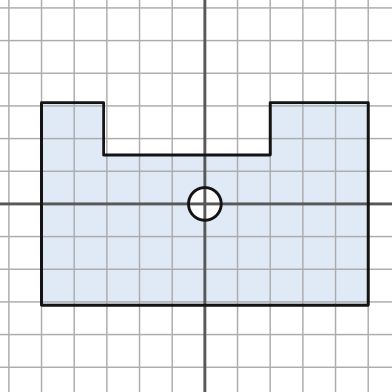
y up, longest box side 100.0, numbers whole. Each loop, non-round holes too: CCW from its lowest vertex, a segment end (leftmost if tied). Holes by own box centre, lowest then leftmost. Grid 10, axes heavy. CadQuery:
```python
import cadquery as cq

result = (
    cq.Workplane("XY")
    .moveTo(-50.0, -31.0)
    .lineTo(50.0, -31.0)
    .lineTo(50.0, 31.0)
    .lineTo(20.0, 31.0)
    .lineTo(20.0, 15.0)
    .lineTo(-31.0, 15.0)
    .lineTo(-31.0, 31.0)
    .lineTo(-50.0, 31.0)
    .close()
    .moveTo(0.0, 0.0)
    .circle(5.0)
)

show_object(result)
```